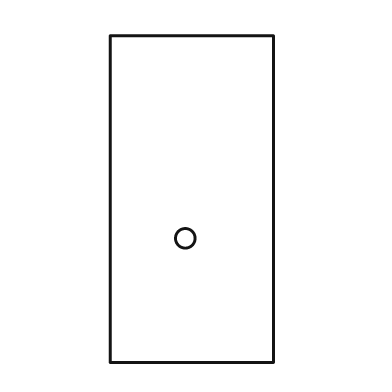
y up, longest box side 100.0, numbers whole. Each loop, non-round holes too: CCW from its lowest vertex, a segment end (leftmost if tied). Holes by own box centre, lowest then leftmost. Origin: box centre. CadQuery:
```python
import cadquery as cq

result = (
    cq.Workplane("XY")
    .moveTo(-25.0, -50.0)
    .lineTo(25.0, -50.0)
    .lineTo(25.0, 50.0)
    .lineTo(-25.0, 50.0)
    .close()
    .moveTo(-2.0, -12.0)
    .circle(3.0)
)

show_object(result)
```